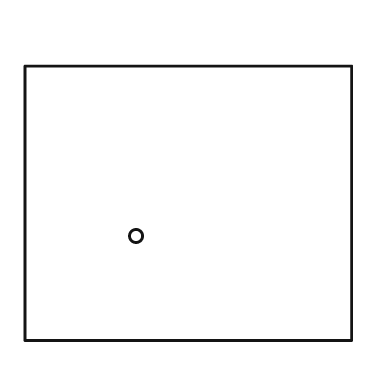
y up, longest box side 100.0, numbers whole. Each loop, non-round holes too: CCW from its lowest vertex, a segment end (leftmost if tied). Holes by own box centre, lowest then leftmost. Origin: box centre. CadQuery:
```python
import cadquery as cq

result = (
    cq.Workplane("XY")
    .moveTo(-50.0, -42.0)
    .lineTo(50.0, -42.0)
    .lineTo(50.0, 42.0)
    .lineTo(-50.0, 42.0)
    .close()
    .moveTo(-16.0, -10.0)
    .circle(2.0)
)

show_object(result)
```